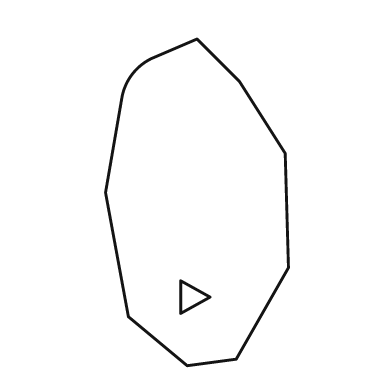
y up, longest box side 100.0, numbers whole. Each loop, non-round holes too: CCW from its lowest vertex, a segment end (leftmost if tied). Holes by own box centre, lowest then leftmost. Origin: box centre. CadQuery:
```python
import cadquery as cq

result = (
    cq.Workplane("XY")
    .moveTo(-3.0, -50.0)
    .lineTo(12.0, -48.0)
    .lineTo(28.0, -20.0)
    .lineTo(27.0, 15.0)
    .lineTo(13.0, 37.0)
    .lineTo(0.0, 50.0)
    .lineTo(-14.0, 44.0)
    .threePointArc((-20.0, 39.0), (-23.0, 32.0))
    .lineTo(-28.0, 3.0)
    .lineTo(-21.0, -35.0)
    .close()
    .moveTo(-5.0, -34.0)
    .lineTo(4.0, -29.0)
    .lineTo(-5.0, -24.0)
    .close()
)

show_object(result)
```